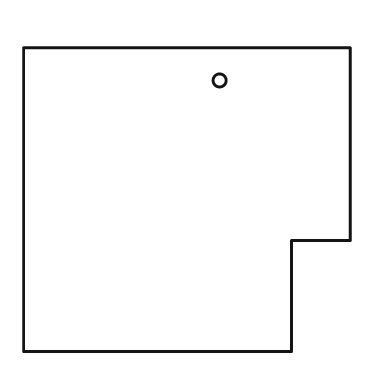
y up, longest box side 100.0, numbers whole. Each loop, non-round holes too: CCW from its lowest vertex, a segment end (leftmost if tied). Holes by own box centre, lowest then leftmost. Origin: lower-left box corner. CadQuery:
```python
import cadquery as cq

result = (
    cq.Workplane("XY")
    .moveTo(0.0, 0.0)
    .lineTo(82.0, 0.0)
    .lineTo(82.0, 34.0)
    .lineTo(100.0, 34.0)
    .lineTo(100.0, 93.0)
    .lineTo(0.0, 93.0)
    .close()
    .moveTo(60.0, 83.0)
    .circle(2.0)
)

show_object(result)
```